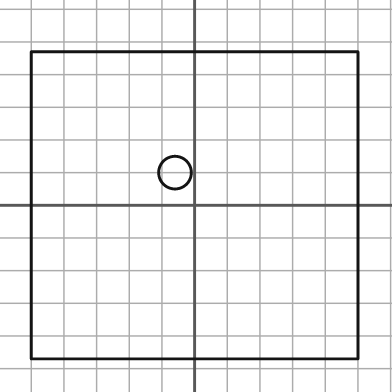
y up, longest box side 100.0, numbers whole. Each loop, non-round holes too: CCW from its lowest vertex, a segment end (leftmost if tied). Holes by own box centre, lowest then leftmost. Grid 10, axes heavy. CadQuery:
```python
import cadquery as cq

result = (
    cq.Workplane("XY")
    .moveTo(-50.0, -47.0)
    .lineTo(50.0, -47.0)
    .lineTo(50.0, 47.0)
    .lineTo(-50.0, 47.0)
    .close()
    .moveTo(-6.0, 10.0)
    .circle(5.0)
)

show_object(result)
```